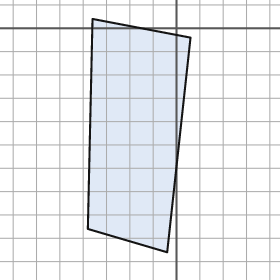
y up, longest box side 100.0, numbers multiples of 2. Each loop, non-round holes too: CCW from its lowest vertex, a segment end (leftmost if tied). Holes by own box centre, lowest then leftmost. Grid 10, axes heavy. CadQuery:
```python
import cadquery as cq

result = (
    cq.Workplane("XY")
    .moveTo(-4.0, -96.0)
    .lineTo(6.0, -4.0)
    .lineTo(-36.0, 4.0)
    .lineTo(-38.0, -86.0)
    .close()
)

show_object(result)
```